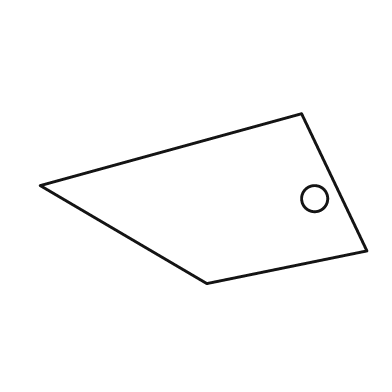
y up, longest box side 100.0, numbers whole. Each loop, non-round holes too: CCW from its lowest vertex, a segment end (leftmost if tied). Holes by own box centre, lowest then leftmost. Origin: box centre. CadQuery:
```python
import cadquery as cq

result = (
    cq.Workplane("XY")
    .moveTo(1.0, -26.0)
    .lineTo(50.0, -16.0)
    .lineTo(30.0, 26.0)
    .lineTo(-50.0, 4.0)
    .close()
    .moveTo(34.0, 0.0)
    .circle(4.0)
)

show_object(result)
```